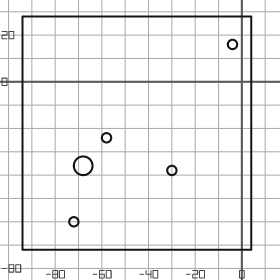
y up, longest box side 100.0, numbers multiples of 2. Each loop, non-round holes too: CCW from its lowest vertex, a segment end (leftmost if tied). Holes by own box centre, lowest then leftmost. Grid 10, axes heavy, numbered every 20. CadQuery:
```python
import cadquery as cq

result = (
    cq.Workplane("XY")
    .moveTo(-94.0, -72.0)
    .lineTo(4.0, -72.0)
    .lineTo(4.0, 28.0)
    .lineTo(-94.0, 28.0)
    .close()
    .moveTo(-72.0, -60.0)
    .circle(2.0)
    .moveTo(-30.0, -38.0)
    .circle(2.0)
    .moveTo(-68.0, -36.0)
    .circle(4.0)
    .moveTo(-58.0, -24.0)
    .circle(2.0)
    .moveTo(-4.0, 16.0)
    .circle(2.0)
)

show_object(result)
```